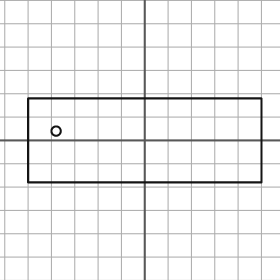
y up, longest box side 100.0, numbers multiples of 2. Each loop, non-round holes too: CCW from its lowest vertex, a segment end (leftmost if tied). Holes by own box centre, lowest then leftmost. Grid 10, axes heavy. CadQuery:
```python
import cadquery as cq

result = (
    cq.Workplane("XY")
    .moveTo(-50.0, -18.0)
    .lineTo(50.0, -18.0)
    .lineTo(50.0, 18.0)
    .lineTo(-50.0, 18.0)
    .close()
    .moveTo(-38.0, 4.0)
    .circle(2.0)
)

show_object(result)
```